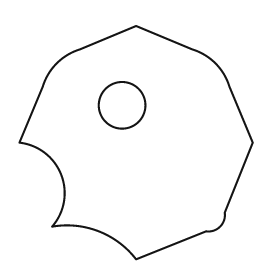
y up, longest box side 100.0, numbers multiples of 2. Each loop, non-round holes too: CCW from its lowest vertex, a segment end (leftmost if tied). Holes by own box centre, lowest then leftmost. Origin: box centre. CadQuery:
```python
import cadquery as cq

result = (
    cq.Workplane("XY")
    .moveTo(0.0, -50.0)
    .lineTo(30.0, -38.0)
    .threePointArc((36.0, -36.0), (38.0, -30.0))
    .lineTo(50.0, 0.0)
    .lineTo(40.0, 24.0)
    .threePointArc((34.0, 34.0), (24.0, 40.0))
    .lineTo(0.0, 50.0)
    .lineTo(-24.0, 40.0)
    .threePointArc((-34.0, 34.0), (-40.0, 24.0))
    .lineTo(-50.0, 0.0)
    .threePointArc((-32.0, -14.0), (-36.0, -36.0))
    .threePointArc((-16.0, -38.0), (0.0, -50.0))
    .close()
    .moveTo(-6.0, 16.0)
    .circle(10.0)
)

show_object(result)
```